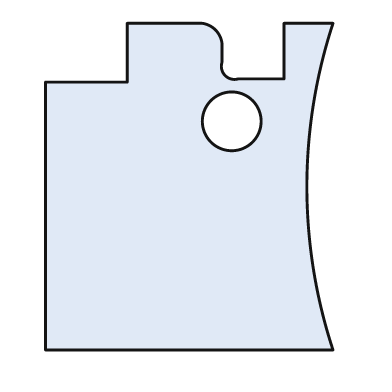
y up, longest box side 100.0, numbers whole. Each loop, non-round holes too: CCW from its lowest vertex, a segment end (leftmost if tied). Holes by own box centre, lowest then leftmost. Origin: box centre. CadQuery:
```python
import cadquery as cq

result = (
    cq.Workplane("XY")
    .moveTo(-44.0, -50.0)
    .lineTo(44.0, -50.0)
    .threePointArc((36.0, 0.0), (44.0, 50.0))
    .lineTo(29.0, 50.0)
    .lineTo(29.0, 33.0)
    .lineTo(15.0, 33.0)
    .threePointArc((11.0, 34.0), (10.0, 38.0))
    .lineTo(10.0, 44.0)
    .threePointArc((8.0, 48.0), (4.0, 50.0))
    .lineTo(-19.0, 50.0)
    .lineTo(-19.0, 32.0)
    .lineTo(-44.0, 32.0)
    .close()
    .moveTo(13.0, 20.0)
    .circle(9.0)
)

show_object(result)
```